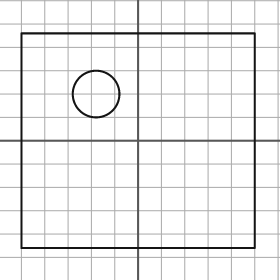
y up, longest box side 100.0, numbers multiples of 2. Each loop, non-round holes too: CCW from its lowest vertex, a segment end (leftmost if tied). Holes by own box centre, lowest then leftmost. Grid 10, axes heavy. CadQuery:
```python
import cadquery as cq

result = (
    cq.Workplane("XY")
    .moveTo(-50.0, -46.0)
    .lineTo(50.0, -46.0)
    .lineTo(50.0, 46.0)
    .lineTo(-50.0, 46.0)
    .close()
    .moveTo(-18.0, 20.0)
    .circle(10.0)
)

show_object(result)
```